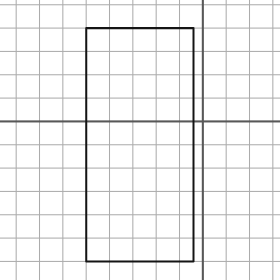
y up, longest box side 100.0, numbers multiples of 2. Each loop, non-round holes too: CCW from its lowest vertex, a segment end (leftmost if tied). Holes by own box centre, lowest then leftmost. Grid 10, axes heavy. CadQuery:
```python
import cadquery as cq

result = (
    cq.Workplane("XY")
    .moveTo(-50.0, -60.0)
    .lineTo(-4.0, -60.0)
    .lineTo(-4.0, 40.0)
    .lineTo(-50.0, 40.0)
    .close()
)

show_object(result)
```